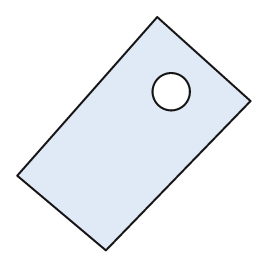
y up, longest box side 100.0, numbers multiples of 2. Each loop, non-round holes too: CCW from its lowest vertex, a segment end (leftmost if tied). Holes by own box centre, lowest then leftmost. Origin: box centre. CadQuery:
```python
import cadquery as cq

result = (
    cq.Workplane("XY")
    .moveTo(-12.0, -50.0)
    .lineTo(50.0, 14.0)
    .lineTo(10.0, 50.0)
    .lineTo(-50.0, -18.0)
    .close()
    .moveTo(16.0, 18.0)
    .circle(8.0)
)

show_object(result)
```